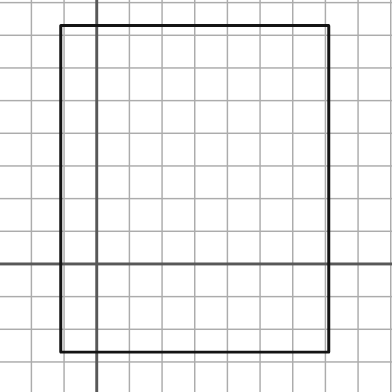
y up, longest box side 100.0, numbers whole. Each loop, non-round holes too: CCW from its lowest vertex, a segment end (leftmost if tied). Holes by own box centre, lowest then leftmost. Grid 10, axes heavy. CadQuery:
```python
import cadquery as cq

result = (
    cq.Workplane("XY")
    .moveTo(-11.0, -27.0)
    .lineTo(71.0, -27.0)
    .lineTo(71.0, 73.0)
    .lineTo(-11.0, 73.0)
    .close()
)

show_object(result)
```